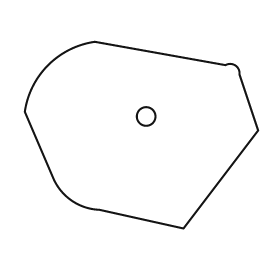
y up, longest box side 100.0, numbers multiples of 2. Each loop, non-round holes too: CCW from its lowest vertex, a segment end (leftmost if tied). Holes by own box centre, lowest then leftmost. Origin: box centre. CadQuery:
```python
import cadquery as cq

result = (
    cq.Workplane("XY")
    .moveTo(18.0, -40.0)
    .lineTo(50.0, 2.0)
    .lineTo(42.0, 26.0)
    .threePointArc((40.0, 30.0), (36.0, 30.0))
    .lineTo(-20.0, 40.0)
    .threePointArc((-40.0, 30.0), (-50.0, 10.0))
    .lineTo(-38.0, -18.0)
    .threePointArc((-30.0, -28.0), (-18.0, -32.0))
    .close()
    .moveTo(2.0, 8.0)
    .circle(4.0)
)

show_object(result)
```